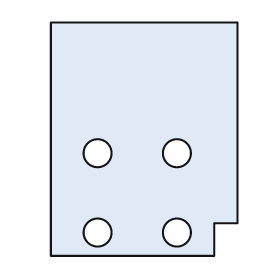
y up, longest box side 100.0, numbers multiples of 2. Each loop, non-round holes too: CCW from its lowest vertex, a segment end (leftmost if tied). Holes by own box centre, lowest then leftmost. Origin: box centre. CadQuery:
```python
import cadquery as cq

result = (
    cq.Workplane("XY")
    .moveTo(-40.0, -50.0)
    .lineTo(30.0, -50.0)
    .lineTo(30.0, -36.0)
    .lineTo(40.0, -36.0)
    .lineTo(40.0, 50.0)
    .lineTo(-40.0, 50.0)
    .close()
    .moveTo(-20.0, -40.0)
    .circle(6.0)
    .moveTo(14.0, -40.0)
    .circle(6.0)
    .moveTo(-20.0, -6.0)
    .circle(6.0)
    .moveTo(14.0, -6.0)
    .circle(6.0)
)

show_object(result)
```